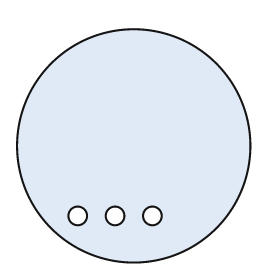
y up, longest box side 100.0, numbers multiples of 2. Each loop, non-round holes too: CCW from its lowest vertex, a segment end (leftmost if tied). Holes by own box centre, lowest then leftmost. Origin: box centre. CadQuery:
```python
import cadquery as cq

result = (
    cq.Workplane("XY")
    .moveTo(0.0, 0.0)
    .circle(50.0)
    .moveTo(-24.0, -30.0)
    .circle(4.0)
    .moveTo(-8.0, -30.0)
    .circle(4.0)
    .moveTo(8.0, -30.0)
    .circle(4.0)
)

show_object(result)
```